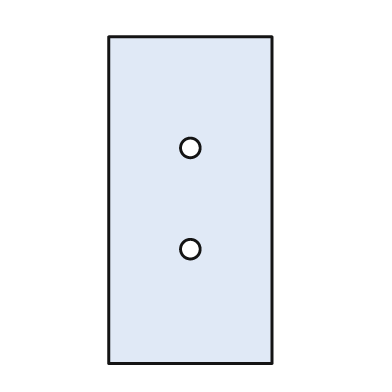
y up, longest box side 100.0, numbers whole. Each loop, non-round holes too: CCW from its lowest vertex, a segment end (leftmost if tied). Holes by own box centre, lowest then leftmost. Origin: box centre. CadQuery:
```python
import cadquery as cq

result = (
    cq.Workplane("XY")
    .moveTo(-25.0, -50.0)
    .lineTo(25.0, -50.0)
    .lineTo(25.0, 50.0)
    .lineTo(-25.0, 50.0)
    .close()
    .moveTo(0.0, -15.0)
    .circle(3.0)
    .moveTo(0.0, 16.0)
    .circle(3.0)
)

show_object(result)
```